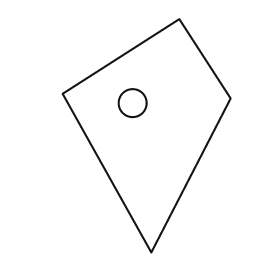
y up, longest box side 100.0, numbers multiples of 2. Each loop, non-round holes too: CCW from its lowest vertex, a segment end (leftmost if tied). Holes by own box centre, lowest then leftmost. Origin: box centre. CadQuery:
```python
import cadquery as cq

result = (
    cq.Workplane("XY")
    .moveTo(2.0, -50.0)
    .lineTo(36.0, 16.0)
    .lineTo(14.0, 50.0)
    .lineTo(-36.0, 18.0)
    .close()
    .moveTo(-6.0, 14.0)
    .circle(6.0)
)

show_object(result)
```